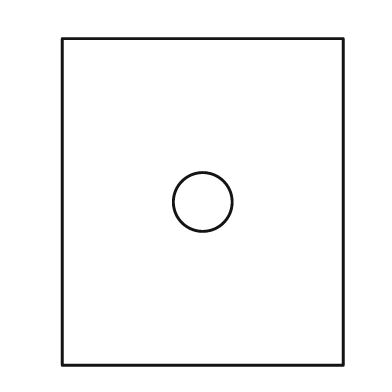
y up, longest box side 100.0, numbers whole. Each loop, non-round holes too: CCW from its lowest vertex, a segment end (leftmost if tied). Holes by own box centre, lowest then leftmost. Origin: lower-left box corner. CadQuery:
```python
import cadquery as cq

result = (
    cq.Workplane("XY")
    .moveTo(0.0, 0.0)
    .lineTo(86.0, 0.0)
    .lineTo(86.0, 100.0)
    .lineTo(0.0, 100.0)
    .close()
    .moveTo(43.0, 50.0)
    .circle(9.0)
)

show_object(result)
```